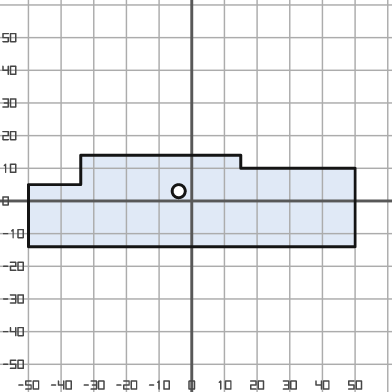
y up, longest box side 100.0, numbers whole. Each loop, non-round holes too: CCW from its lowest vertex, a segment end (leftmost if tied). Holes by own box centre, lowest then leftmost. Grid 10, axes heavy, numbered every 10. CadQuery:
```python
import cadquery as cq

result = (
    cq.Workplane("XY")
    .moveTo(-50.0, -14.0)
    .lineTo(50.0, -14.0)
    .lineTo(50.0, 10.0)
    .lineTo(15.0, 10.0)
    .lineTo(15.0, 14.0)
    .lineTo(-34.0, 14.0)
    .lineTo(-34.0, 5.0)
    .lineTo(-50.0, 5.0)
    .close()
    .moveTo(-4.0, 3.0)
    .circle(2.0)
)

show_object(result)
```